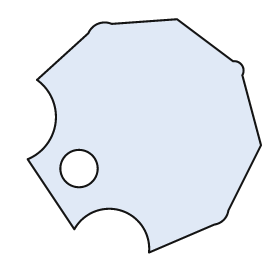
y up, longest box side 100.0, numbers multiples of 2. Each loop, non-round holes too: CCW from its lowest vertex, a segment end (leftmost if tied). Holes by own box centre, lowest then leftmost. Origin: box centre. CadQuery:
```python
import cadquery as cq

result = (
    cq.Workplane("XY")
    .moveTo(2.0, -50.0)
    .lineTo(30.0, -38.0)
    .threePointArc((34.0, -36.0), (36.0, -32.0))
    .lineTo(50.0, -4.0)
    .lineTo(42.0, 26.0)
    .threePointArc((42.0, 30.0), (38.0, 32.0))
    .lineTo(14.0, 50.0)
    .lineTo(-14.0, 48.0)
    .threePointArc((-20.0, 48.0), (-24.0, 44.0))
    .lineTo(-46.0, 24.0)
    .threePointArc((-38.0, 6.0), (-50.0, -10.0))
    .lineTo(-30.0, -40.0)
    .threePointArc((-10.0, -32.0), (2.0, -50.0))
    .close()
    .moveTo(-28.0, -14.0)
    .circle(8.0)
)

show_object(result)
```